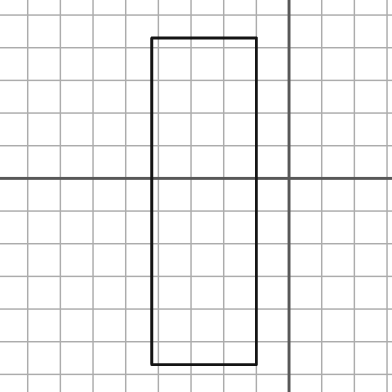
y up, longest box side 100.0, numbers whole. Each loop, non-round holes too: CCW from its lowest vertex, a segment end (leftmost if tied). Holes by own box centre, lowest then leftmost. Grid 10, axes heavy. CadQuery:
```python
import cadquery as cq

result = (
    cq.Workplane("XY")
    .moveTo(-42.0, -57.0)
    .lineTo(-10.0, -57.0)
    .lineTo(-10.0, 43.0)
    .lineTo(-42.0, 43.0)
    .close()
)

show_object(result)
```